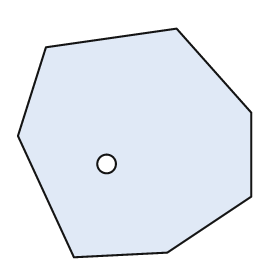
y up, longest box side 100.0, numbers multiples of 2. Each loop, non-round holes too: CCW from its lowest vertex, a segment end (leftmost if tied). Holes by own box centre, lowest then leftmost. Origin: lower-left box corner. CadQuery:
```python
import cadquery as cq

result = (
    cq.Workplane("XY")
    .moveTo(24.0, 0.0)
    .lineTo(64.0, 2.0)
    .lineTo(100.0, 26.0)
    .lineTo(100.0, 62.0)
    .lineTo(68.0, 98.0)
    .lineTo(12.0, 90.0)
    .lineTo(0.0, 52.0)
    .close()
    .moveTo(38.0, 40.0)
    .circle(4.0)
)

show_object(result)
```